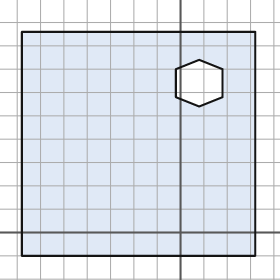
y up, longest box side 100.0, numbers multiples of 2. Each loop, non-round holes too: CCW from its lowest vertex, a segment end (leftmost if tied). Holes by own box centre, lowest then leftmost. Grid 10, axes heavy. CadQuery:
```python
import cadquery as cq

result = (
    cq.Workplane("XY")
    .moveTo(-68.0, -10.0)
    .lineTo(32.0, -10.0)
    .lineTo(32.0, 86.0)
    .lineTo(-68.0, 86.0)
    .close()
    .moveTo(8.0, 54.0)
    .lineTo(18.0, 58.0)
    .lineTo(18.0, 70.0)
    .lineTo(8.0, 74.0)
    .lineTo(-2.0, 70.0)
    .lineTo(-2.0, 58.0)
    .close()
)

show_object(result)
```